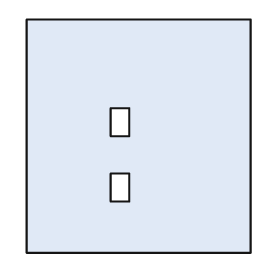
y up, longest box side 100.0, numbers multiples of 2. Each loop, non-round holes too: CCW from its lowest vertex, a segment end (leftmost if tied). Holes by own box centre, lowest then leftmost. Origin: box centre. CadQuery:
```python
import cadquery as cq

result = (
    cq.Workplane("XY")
    .moveTo(-48.0, -50.0)
    .lineTo(48.0, -50.0)
    .lineTo(48.0, 50.0)
    .lineTo(-48.0, 50.0)
    .close()
    .moveTo(-12.0, -28.0)
    .lineTo(-4.0, -28.0)
    .lineTo(-4.0, -16.0)
    .lineTo(-12.0, -16.0)
    .close()
    .moveTo(-12.0, 0.0)
    .lineTo(-4.0, 0.0)
    .lineTo(-4.0, 12.0)
    .lineTo(-12.0, 12.0)
    .close()
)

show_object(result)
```